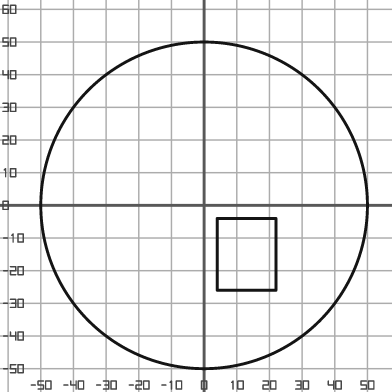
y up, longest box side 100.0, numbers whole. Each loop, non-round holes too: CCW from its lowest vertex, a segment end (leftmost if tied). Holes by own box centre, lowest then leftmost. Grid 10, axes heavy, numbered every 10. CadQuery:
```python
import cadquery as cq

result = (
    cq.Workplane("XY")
    .moveTo(0.0, 0.0)
    .circle(50.0)
    .moveTo(4.0, -26.0)
    .lineTo(22.0, -26.0)
    .lineTo(22.0, -4.0)
    .lineTo(4.0, -4.0)
    .close()
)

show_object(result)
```